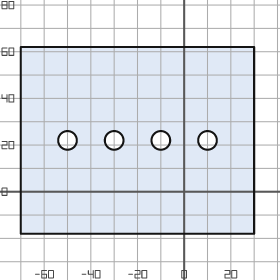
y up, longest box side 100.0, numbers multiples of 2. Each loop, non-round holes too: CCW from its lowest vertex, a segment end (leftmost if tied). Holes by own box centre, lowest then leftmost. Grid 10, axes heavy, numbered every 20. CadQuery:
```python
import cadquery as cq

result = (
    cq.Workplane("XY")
    .moveTo(-70.0, -18.0)
    .lineTo(30.0, -18.0)
    .lineTo(30.0, 62.0)
    .lineTo(-70.0, 62.0)
    .close()
    .moveTo(-50.0, 22.0)
    .circle(4.0)
    .moveTo(-30.0, 22.0)
    .circle(4.0)
    .moveTo(-10.0, 22.0)
    .circle(4.0)
    .moveTo(10.0, 22.0)
    .circle(4.0)
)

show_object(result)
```